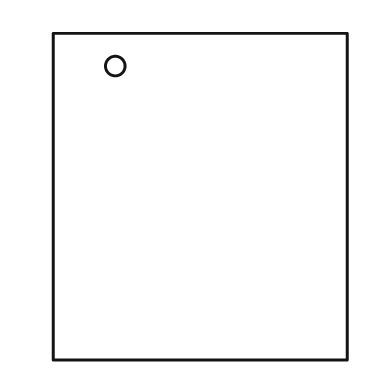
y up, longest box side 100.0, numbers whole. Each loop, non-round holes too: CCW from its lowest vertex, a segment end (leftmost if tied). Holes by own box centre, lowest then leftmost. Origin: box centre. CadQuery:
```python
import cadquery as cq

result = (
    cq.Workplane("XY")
    .moveTo(-45.0, -50.0)
    .lineTo(45.0, -50.0)
    .lineTo(45.0, 50.0)
    .lineTo(-45.0, 50.0)
    .close()
    .moveTo(-26.0, 40.0)
    .circle(3.0)
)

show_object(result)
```